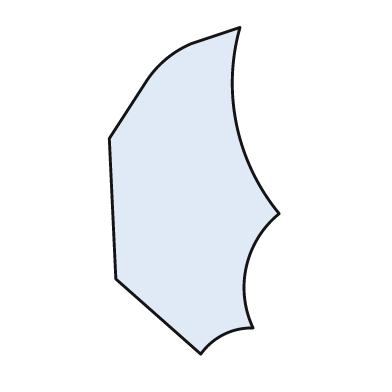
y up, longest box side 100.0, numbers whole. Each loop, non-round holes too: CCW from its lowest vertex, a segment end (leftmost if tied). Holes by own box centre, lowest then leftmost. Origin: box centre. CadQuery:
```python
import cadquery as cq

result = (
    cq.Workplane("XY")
    .moveTo(2.0, -50.0)
    .threePointArc((9.0, -44.0), (18.0, -42.0))
    .threePointArc((16.0, -23.0), (26.0, -7.0))
    .threePointArc((13.0, 20.0), (14.0, 50.0))
    .lineTo(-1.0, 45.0)
    .threePointArc((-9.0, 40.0), (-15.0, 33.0))
    .lineTo(-26.0, 16.0)
    .lineTo(-24.0, -27.0)
    .close()
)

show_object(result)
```